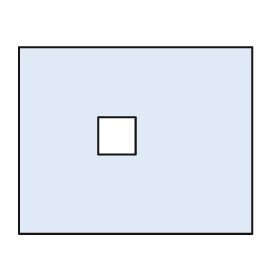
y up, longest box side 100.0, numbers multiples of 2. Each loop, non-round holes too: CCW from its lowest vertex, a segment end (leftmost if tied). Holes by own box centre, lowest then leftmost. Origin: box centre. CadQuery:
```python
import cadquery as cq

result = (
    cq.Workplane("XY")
    .moveTo(-50.0, -40.0)
    .lineTo(50.0, -40.0)
    .lineTo(50.0, 40.0)
    .lineTo(-50.0, 40.0)
    .close()
    .moveTo(-16.0, -6.0)
    .lineTo(0.0, -6.0)
    .lineTo(0.0, 10.0)
    .lineTo(-16.0, 10.0)
    .close()
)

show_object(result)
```